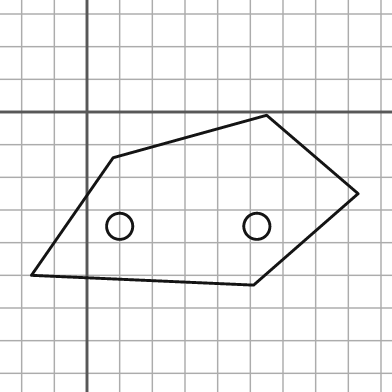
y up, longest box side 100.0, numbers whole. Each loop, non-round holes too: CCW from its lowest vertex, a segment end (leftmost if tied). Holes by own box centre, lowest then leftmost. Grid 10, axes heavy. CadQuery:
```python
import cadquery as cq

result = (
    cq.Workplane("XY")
    .moveTo(51.0, -53.0)
    .lineTo(83.0, -25.0)
    .lineTo(55.0, -1.0)
    .lineTo(8.0, -14.0)
    .lineTo(-17.0, -50.0)
    .close()
    .moveTo(10.0, -35.0)
    .circle(4.0)
    .moveTo(52.0, -35.0)
    .circle(4.0)
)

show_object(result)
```